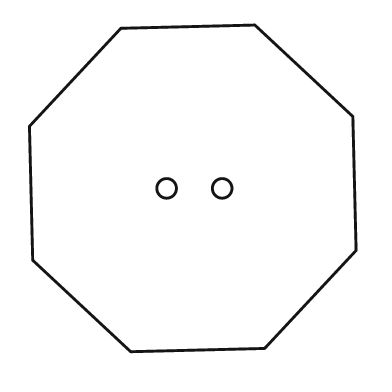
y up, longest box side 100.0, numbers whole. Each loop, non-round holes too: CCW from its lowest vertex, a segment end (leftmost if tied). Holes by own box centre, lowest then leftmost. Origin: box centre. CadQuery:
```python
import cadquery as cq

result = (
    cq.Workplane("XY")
    .moveTo(-19.0, -50.0)
    .lineTo(22.0, -49.0)
    .lineTo(50.0, -19.0)
    .lineTo(49.0, 22.0)
    .lineTo(19.0, 50.0)
    .lineTo(-22.0, 49.0)
    .lineTo(-50.0, 19.0)
    .lineTo(-49.0, -22.0)
    .close()
    .moveTo(-8.0, 0.0)
    .circle(3.0)
    .moveTo(9.0, 0.0)
    .circle(3.0)
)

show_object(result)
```